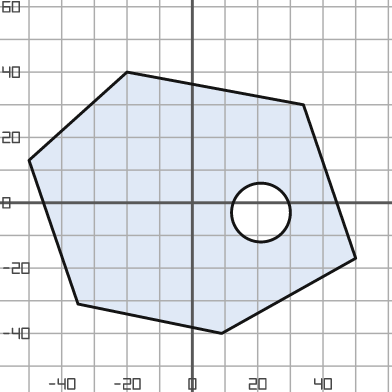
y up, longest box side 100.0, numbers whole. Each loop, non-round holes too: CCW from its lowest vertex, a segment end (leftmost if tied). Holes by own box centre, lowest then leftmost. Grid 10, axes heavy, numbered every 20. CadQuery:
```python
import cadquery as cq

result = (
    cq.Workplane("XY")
    .moveTo(9.0, -40.0)
    .lineTo(50.0, -17.0)
    .lineTo(34.0, 30.0)
    .lineTo(-20.0, 40.0)
    .lineTo(-50.0, 13.0)
    .lineTo(-35.0, -31.0)
    .close()
    .moveTo(21.0, -3.0)
    .circle(9.0)
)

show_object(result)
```